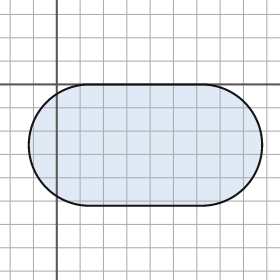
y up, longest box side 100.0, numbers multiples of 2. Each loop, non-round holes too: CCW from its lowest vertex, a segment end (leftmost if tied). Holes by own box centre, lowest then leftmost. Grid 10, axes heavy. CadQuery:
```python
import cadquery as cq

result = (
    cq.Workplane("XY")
    .moveTo(14.0, -52.0)
    .lineTo(62.0, -52.0)
    .threePointArc((88.0, -26.0), (62.0, 0.0))
    .lineTo(14.0, 0.0)
    .threePointArc((-12.0, -26.0), (14.0, -52.0))
    .close()
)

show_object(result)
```